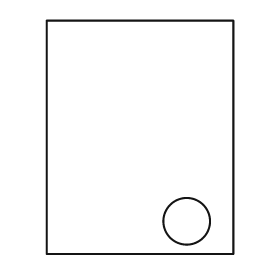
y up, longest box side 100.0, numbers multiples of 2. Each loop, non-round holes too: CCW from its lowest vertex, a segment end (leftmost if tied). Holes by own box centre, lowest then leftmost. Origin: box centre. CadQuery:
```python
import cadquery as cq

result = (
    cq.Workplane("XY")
    .moveTo(-40.0, -50.0)
    .lineTo(40.0, -50.0)
    .lineTo(40.0, 50.0)
    .lineTo(-40.0, 50.0)
    .close()
    .moveTo(20.0, -36.0)
    .circle(10.0)
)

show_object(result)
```